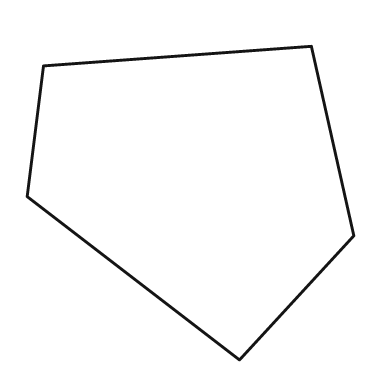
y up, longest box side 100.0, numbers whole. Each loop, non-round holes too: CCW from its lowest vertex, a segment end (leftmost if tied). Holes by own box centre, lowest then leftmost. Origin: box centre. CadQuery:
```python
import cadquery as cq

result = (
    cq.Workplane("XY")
    .moveTo(15.0, -48.0)
    .lineTo(50.0, -10.0)
    .lineTo(37.0, 48.0)
    .lineTo(-45.0, 42.0)
    .lineTo(-50.0, 2.0)
    .close()
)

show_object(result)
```